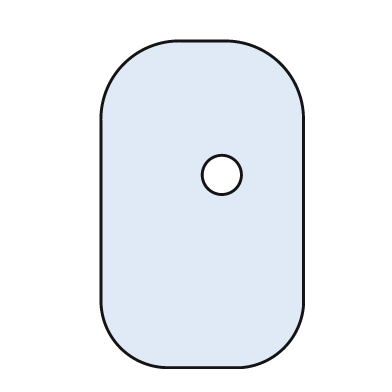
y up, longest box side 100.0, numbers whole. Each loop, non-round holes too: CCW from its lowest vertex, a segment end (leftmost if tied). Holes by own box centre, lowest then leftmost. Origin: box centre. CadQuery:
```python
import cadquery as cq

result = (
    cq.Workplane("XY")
    .moveTo(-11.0, -50.0)
    .lineTo(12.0, -50.0)
    .threePointArc((25.0, -44.0), (31.0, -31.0))
    .lineTo(31.0, 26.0)
    .threePointArc((24.0, 43.0), (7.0, 50.0))
    .lineTo(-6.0, 50.0)
    .threePointArc((-24.0, 43.0), (-31.0, 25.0))
    .lineTo(-31.0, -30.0)
    .threePointArc((-25.0, -44.0), (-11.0, -50.0))
    .close()
    .moveTo(6.0, 9.0)
    .circle(6.0)
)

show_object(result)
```